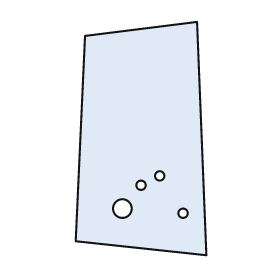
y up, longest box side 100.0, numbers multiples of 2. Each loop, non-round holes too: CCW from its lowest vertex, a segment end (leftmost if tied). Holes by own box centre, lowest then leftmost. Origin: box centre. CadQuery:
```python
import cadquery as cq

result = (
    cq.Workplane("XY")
    .moveTo(28.0, -50.0)
    .lineTo(24.0, 50.0)
    .lineTo(-24.0, 44.0)
    .lineTo(-28.0, -44.0)
    .close()
    .moveTo(18.0, -32.0)
    .circle(2.0)
    .moveTo(-8.0, -30.0)
    .circle(4.0)
    .moveTo(0.0, -20.0)
    .circle(2.0)
    .moveTo(8.0, -16.0)
    .circle(2.0)
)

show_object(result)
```